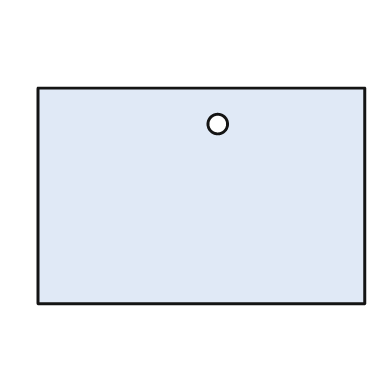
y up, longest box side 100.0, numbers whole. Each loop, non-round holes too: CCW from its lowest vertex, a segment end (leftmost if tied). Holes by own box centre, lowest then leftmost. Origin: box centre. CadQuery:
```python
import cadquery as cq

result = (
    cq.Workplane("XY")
    .moveTo(-50.0, -33.0)
    .lineTo(50.0, -33.0)
    .lineTo(50.0, 33.0)
    .lineTo(-50.0, 33.0)
    .close()
    .moveTo(5.0, 22.0)
    .circle(3.0)
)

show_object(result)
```